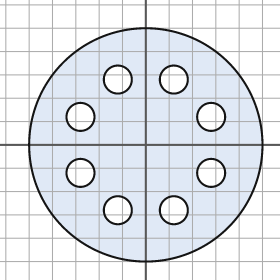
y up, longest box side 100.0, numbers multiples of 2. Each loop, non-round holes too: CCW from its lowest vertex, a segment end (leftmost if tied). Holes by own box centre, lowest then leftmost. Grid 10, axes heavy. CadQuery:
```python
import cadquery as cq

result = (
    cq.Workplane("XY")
    .moveTo(0.0, 0.0)
    .circle(50.0)
    .moveTo(-12.0, -28.0)
    .circle(6.0)
    .moveTo(12.0, -28.0)
    .circle(6.0)
    .moveTo(-28.0, -12.0)
    .circle(6.0)
    .moveTo(28.0, -12.0)
    .circle(6.0)
    .moveTo(-28.0, 12.0)
    .circle(6.0)
    .moveTo(28.0, 12.0)
    .circle(6.0)
    .moveTo(-12.0, 28.0)
    .circle(6.0)
    .moveTo(12.0, 28.0)
    .circle(6.0)
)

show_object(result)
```